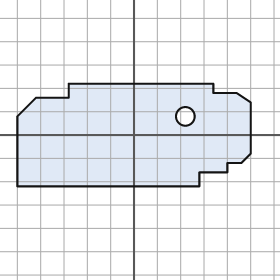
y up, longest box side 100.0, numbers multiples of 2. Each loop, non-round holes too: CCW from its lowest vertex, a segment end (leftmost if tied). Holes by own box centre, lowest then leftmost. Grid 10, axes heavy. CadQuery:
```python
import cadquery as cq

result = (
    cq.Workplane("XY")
    .moveTo(-50.0, -22.0)
    .lineTo(28.0, -22.0)
    .lineTo(28.0, -16.0)
    .lineTo(40.0, -16.0)
    .lineTo(40.0, -12.0)
    .lineTo(46.0, -12.0)
    .lineTo(50.0, -8.0)
    .lineTo(50.0, 14.0)
    .lineTo(44.0, 18.0)
    .lineTo(34.0, 18.0)
    .lineTo(34.0, 22.0)
    .lineTo(-28.0, 22.0)
    .lineTo(-28.0, 16.0)
    .lineTo(-42.0, 16.0)
    .lineTo(-50.0, 8.0)
    .close()
    .moveTo(22.0, 8.0)
    .circle(4.0)
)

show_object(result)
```